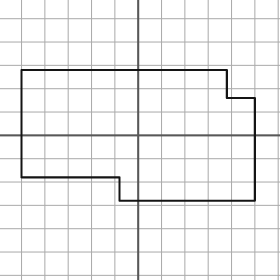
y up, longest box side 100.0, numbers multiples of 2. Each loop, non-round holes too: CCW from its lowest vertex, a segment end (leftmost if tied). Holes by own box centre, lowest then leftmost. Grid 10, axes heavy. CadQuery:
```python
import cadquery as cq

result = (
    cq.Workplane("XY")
    .moveTo(-8.0, -28.0)
    .lineTo(50.0, -28.0)
    .lineTo(50.0, 16.0)
    .lineTo(38.0, 16.0)
    .lineTo(38.0, 28.0)
    .lineTo(-50.0, 28.0)
    .lineTo(-50.0, -18.0)
    .lineTo(-8.0, -18.0)
    .close()
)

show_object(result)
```